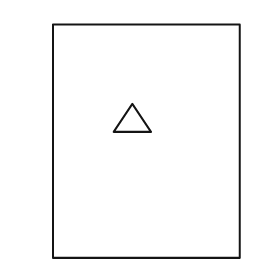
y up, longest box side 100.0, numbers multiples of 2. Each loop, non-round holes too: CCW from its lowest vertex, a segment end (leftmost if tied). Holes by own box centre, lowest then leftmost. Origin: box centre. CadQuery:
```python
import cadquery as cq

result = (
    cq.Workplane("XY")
    .moveTo(-40.0, -50.0)
    .lineTo(40.0, -50.0)
    .lineTo(40.0, 50.0)
    .lineTo(-40.0, 50.0)
    .close()
    .moveTo(-14.0, 4.0)
    .lineTo(2.0, 4.0)
    .lineTo(-6.0, 16.0)
    .close()
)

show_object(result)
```